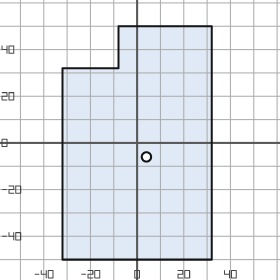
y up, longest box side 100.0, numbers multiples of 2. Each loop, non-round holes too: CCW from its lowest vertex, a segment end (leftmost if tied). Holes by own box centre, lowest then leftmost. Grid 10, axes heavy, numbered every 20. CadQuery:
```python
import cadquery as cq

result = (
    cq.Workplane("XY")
    .moveTo(-32.0, -50.0)
    .lineTo(32.0, -50.0)
    .lineTo(32.0, 50.0)
    .lineTo(-8.0, 50.0)
    .lineTo(-8.0, 32.0)
    .lineTo(-32.0, 32.0)
    .close()
    .moveTo(4.0, -6.0)
    .circle(2.0)
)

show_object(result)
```